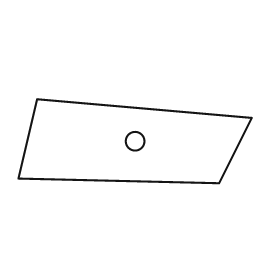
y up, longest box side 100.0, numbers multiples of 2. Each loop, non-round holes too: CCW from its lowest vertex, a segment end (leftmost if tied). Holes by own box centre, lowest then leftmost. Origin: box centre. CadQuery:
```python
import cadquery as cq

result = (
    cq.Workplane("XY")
    .moveTo(36.0, -18.0)
    .lineTo(50.0, 10.0)
    .lineTo(-42.0, 18.0)
    .lineTo(-50.0, -16.0)
    .close()
    .moveTo(0.0, 0.0)
    .circle(4.0)
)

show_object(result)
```